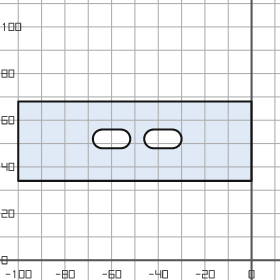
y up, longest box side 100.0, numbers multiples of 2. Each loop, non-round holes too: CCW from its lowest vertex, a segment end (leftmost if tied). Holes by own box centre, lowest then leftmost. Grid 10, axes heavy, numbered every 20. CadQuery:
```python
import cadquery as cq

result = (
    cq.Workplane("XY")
    .moveTo(-100.0, 34.0)
    .lineTo(0.0, 34.0)
    .lineTo(0.0, 68.0)
    .lineTo(-100.0, 68.0)
    .close()
    .moveTo(-64.0, 48.0)
    .lineTo(-56.0, 48.0)
    .threePointArc((-52.0, 52.0), (-56.0, 56.0))
    .lineTo(-64.0, 56.0)
    .threePointArc((-68.0, 52.0), (-64.0, 48.0))
    .close()
    .moveTo(-42.0, 48.0)
    .lineTo(-34.0, 48.0)
    .threePointArc((-30.0, 52.0), (-34.0, 56.0))
    .lineTo(-42.0, 56.0)
    .threePointArc((-46.0, 52.0), (-42.0, 48.0))
    .close()
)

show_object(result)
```